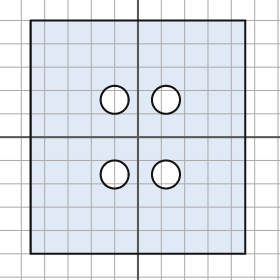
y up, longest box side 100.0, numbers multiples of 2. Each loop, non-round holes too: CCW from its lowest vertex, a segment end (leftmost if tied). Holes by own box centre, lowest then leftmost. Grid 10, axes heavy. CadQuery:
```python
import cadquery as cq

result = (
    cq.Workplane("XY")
    .moveTo(-46.0, -50.0)
    .lineTo(46.0, -50.0)
    .lineTo(46.0, 50.0)
    .lineTo(-46.0, 50.0)
    .close()
    .moveTo(-10.0, -16.0)
    .circle(6.0)
    .moveTo(12.0, -16.0)
    .circle(6.0)
    .moveTo(-10.0, 16.0)
    .circle(6.0)
    .moveTo(12.0, 16.0)
    .circle(6.0)
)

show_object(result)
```